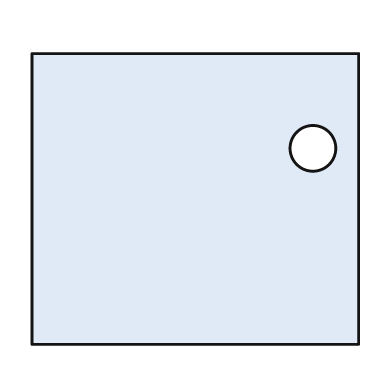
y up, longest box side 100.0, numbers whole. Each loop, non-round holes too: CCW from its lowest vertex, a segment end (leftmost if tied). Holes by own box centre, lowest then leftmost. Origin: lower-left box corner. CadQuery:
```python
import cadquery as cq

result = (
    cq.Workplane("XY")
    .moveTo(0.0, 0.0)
    .lineTo(100.0, 0.0)
    .lineTo(100.0, 89.0)
    .lineTo(0.0, 89.0)
    .close()
    .moveTo(86.0, 60.0)
    .circle(7.0)
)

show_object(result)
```